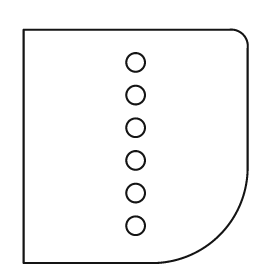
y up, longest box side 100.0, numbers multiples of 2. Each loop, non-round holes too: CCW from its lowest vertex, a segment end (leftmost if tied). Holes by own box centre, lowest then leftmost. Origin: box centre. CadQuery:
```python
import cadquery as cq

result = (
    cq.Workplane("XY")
    .moveTo(-48.0, -50.0)
    .lineTo(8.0, -50.0)
    .threePointArc((36.0, -38.0), (48.0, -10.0))
    .lineTo(48.0, 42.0)
    .threePointArc((46.0, 48.0), (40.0, 50.0))
    .lineTo(-48.0, 50.0)
    .close()
    .moveTo(0.0, -34.0)
    .circle(4.0)
    .moveTo(0.0, -20.0)
    .circle(4.0)
    .moveTo(0.0, -6.0)
    .circle(4.0)
    .moveTo(0.0, 8.0)
    .circle(4.0)
    .moveTo(0.0, 22.0)
    .circle(4.0)
    .moveTo(0.0, 36.0)
    .circle(4.0)
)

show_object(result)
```